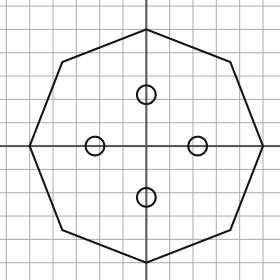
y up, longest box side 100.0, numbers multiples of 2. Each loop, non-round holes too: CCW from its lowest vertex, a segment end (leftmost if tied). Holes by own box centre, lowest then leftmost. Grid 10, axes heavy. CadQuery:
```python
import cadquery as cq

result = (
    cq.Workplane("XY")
    .moveTo(0.0, -50.0)
    .lineTo(36.0, -36.0)
    .lineTo(50.0, 0.0)
    .lineTo(36.0, 36.0)
    .lineTo(0.0, 50.0)
    .lineTo(-36.0, 36.0)
    .lineTo(-50.0, 0.0)
    .lineTo(-36.0, -36.0)
    .close()
    .moveTo(0.0, -22.0)
    .circle(4.0)
    .moveTo(-22.0, 0.0)
    .circle(4.0)
    .moveTo(22.0, 0.0)
    .circle(4.0)
    .moveTo(0.0, 22.0)
    .circle(4.0)
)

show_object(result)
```